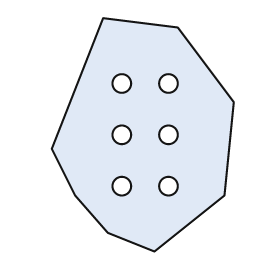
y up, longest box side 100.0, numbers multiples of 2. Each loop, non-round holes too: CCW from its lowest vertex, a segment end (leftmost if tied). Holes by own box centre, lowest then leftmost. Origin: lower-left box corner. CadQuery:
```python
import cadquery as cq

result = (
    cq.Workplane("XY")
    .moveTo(44.0, 0.0)
    .lineTo(74.0, 24.0)
    .lineTo(78.0, 64.0)
    .lineTo(54.0, 96.0)
    .lineTo(22.0, 100.0)
    .lineTo(0.0, 44.0)
    .lineTo(10.0, 24.0)
    .lineTo(24.0, 8.0)
    .close()
    .moveTo(30.0, 28.0)
    .circle(4.0)
    .moveTo(50.0, 28.0)
    .circle(4.0)
    .moveTo(30.0, 50.0)
    .circle(4.0)
    .moveTo(50.0, 50.0)
    .circle(4.0)
    .moveTo(30.0, 72.0)
    .circle(4.0)
    .moveTo(50.0, 72.0)
    .circle(4.0)
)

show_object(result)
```